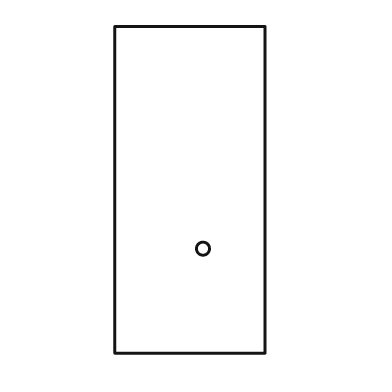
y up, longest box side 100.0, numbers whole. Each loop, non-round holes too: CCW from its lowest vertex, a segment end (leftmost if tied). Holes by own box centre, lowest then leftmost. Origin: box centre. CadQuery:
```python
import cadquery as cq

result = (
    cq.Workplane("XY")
    .moveTo(-23.0, -50.0)
    .lineTo(23.0, -50.0)
    .lineTo(23.0, 50.0)
    .lineTo(-23.0, 50.0)
    .close()
    .moveTo(4.0, -18.0)
    .circle(2.0)
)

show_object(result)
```